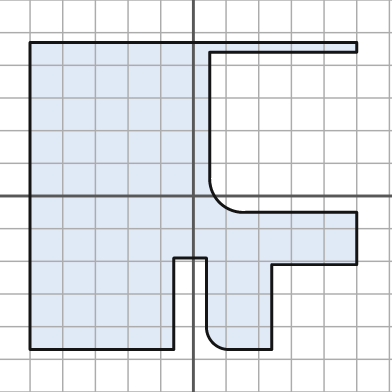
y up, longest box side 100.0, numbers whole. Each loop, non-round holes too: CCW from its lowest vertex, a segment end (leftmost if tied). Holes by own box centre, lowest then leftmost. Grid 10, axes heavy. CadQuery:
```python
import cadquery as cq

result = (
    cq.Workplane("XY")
    .moveTo(-50.0, -47.0)
    .lineTo(-6.0, -47.0)
    .lineTo(-6.0, -19.0)
    .lineTo(4.0, -19.0)
    .lineTo(4.0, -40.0)
    .threePointArc((6.0, -45.0), (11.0, -47.0))
    .lineTo(24.0, -47.0)
    .lineTo(24.0, -21.0)
    .lineTo(50.0, -21.0)
    .lineTo(50.0, -5.0)
    .lineTo(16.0, -5.0)
    .threePointArc((8.0, -2.0), (5.0, 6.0))
    .lineTo(5.0, 44.0)
    .lineTo(50.0, 44.0)
    .lineTo(50.0, 47.0)
    .lineTo(-50.0, 47.0)
    .close()
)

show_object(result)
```